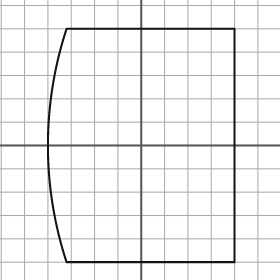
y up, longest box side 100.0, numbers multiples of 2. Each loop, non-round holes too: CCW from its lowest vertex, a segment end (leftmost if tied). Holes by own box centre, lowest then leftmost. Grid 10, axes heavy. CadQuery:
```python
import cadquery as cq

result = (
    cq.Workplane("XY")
    .moveTo(-32.0, -50.0)
    .lineTo(40.0, -50.0)
    .lineTo(40.0, 50.0)
    .lineTo(-32.0, 50.0)
    .threePointArc((-40.0, 0.0), (-32.0, -50.0))
    .close()
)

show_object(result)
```